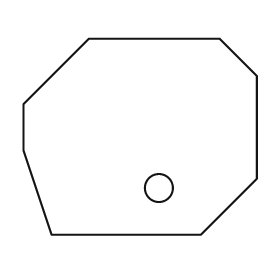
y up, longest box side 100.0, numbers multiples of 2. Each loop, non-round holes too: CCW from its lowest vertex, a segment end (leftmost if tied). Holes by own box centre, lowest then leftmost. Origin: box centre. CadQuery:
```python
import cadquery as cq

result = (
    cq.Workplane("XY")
    .moveTo(-38.0, -42.0)
    .lineTo(26.0, -42.0)
    .lineTo(50.0, -18.0)
    .lineTo(50.0, 26.0)
    .lineTo(34.0, 42.0)
    .lineTo(-22.0, 42.0)
    .lineTo(-50.0, 14.0)
    .lineTo(-50.0, -6.0)
    .close()
    .moveTo(8.0, -22.0)
    .circle(6.0)
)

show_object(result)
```